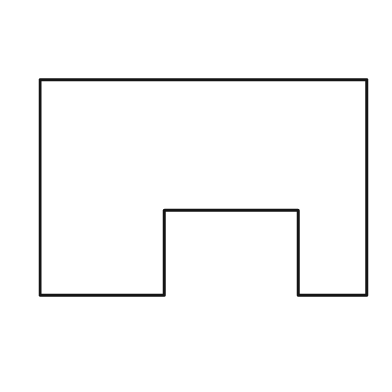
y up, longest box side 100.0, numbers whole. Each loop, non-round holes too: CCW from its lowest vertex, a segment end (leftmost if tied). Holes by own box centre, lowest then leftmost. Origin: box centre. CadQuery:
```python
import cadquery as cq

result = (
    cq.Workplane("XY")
    .moveTo(-50.0, -33.0)
    .lineTo(-12.0, -33.0)
    .lineTo(-12.0, -7.0)
    .lineTo(29.0, -7.0)
    .lineTo(29.0, -33.0)
    .lineTo(50.0, -33.0)
    .lineTo(50.0, 33.0)
    .lineTo(-50.0, 33.0)
    .close()
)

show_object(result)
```